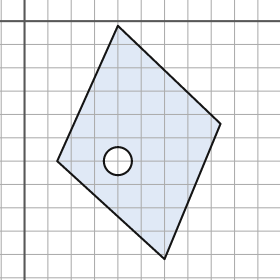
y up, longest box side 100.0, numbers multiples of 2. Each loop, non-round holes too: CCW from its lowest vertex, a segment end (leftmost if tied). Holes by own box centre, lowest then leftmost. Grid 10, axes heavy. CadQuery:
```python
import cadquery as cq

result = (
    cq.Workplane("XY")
    .moveTo(60.0, -102.0)
    .lineTo(84.0, -44.0)
    .lineTo(40.0, -2.0)
    .lineTo(14.0, -60.0)
    .close()
    .moveTo(40.0, -60.0)
    .circle(6.0)
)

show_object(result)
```